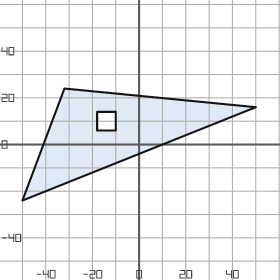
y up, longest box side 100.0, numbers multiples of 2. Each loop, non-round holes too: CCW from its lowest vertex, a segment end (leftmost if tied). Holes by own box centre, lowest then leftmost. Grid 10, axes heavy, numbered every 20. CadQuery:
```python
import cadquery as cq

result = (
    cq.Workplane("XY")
    .moveTo(-50.0, -24.0)
    .lineTo(50.0, 16.0)
    .lineTo(-32.0, 24.0)
    .close()
    .moveTo(-18.0, 6.0)
    .lineTo(-10.0, 6.0)
    .lineTo(-10.0, 14.0)
    .lineTo(-18.0, 14.0)
    .close()
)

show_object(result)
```